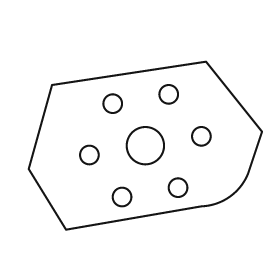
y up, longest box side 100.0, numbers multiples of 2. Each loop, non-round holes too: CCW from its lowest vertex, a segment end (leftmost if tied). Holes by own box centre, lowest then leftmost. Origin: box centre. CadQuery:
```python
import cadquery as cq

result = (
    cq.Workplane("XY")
    .moveTo(-34.0, -36.0)
    .lineTo(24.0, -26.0)
    .threePointArc((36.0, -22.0), (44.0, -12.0))
    .lineTo(50.0, 6.0)
    .lineTo(26.0, 36.0)
    .lineTo(-40.0, 26.0)
    .lineTo(-50.0, -10.0)
    .close()
    .moveTo(-10.0, -22.0)
    .circle(4.0)
    .moveTo(14.0, -18.0)
    .circle(4.0)
    .moveTo(-24.0, -4.0)
    .circle(4.0)
    .moveTo(0.0, 0.0)
    .circle(8.0)
    .moveTo(24.0, 4.0)
    .circle(4.0)
    .moveTo(-14.0, 18.0)
    .circle(4.0)
    .moveTo(10.0, 22.0)
    .circle(4.0)
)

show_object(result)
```